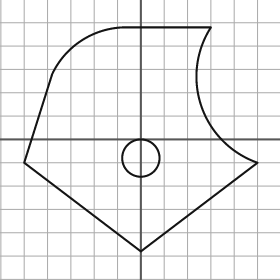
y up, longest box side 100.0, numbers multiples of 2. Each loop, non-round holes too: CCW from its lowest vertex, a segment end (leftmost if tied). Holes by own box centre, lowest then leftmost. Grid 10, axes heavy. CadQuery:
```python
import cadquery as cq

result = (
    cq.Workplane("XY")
    .moveTo(0.0, -48.0)
    .lineTo(50.0, -10.0)
    .threePointArc((26.0, 14.0), (30.0, 48.0))
    .lineTo(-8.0, 48.0)
    .threePointArc((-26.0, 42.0), (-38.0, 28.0))
    .lineTo(-50.0, -10.0)
    .close()
    .moveTo(0.0, -8.0)
    .circle(8.0)
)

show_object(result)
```